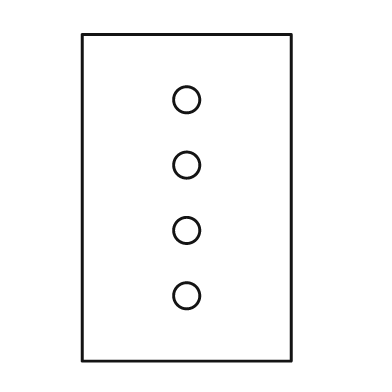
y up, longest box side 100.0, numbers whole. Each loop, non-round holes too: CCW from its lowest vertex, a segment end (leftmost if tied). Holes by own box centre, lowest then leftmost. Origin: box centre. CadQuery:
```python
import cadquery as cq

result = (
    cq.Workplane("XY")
    .moveTo(-32.0, -50.0)
    .lineTo(32.0, -50.0)
    .lineTo(32.0, 50.0)
    .lineTo(-32.0, 50.0)
    .close()
    .moveTo(0.0, -30.0)
    .circle(4.0)
    .moveTo(0.0, -10.0)
    .circle(4.0)
    .moveTo(0.0, 10.0)
    .circle(4.0)
    .moveTo(0.0, 30.0)
    .circle(4.0)
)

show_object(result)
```